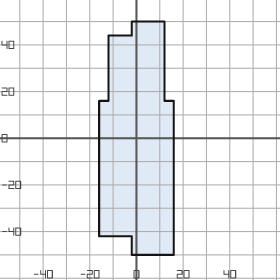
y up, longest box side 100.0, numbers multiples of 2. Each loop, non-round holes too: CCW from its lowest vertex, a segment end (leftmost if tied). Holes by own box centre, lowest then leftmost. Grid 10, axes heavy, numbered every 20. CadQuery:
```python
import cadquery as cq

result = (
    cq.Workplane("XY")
    .moveTo(-2.0, -50.0)
    .lineTo(16.0, -50.0)
    .lineTo(16.0, 16.0)
    .lineTo(12.0, 16.0)
    .lineTo(12.0, 50.0)
    .lineTo(-2.0, 50.0)
    .lineTo(-2.0, 44.0)
    .lineTo(-12.0, 44.0)
    .lineTo(-12.0, 16.0)
    .lineTo(-16.0, 16.0)
    .lineTo(-16.0, -42.0)
    .lineTo(-2.0, -42.0)
    .close()
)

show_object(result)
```